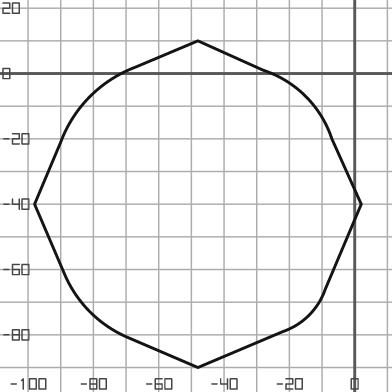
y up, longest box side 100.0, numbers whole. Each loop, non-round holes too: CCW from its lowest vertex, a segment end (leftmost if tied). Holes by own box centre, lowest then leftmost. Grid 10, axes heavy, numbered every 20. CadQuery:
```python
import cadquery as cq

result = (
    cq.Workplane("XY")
    .moveTo(-48.0, -90.0)
    .lineTo(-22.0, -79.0)
    .threePointArc((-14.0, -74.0), (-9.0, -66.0))
    .lineTo(2.0, -40.0)
    .lineTo(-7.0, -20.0)
    .threePointArc((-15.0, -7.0), (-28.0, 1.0))
    .lineTo(-48.0, 10.0)
    .lineTo(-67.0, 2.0)
    .threePointArc((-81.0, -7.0), (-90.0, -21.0))
    .lineTo(-98.0, -40.0)
    .lineTo(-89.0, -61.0)
    .threePointArc((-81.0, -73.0), (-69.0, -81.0))
    .close()
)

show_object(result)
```